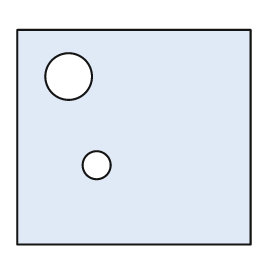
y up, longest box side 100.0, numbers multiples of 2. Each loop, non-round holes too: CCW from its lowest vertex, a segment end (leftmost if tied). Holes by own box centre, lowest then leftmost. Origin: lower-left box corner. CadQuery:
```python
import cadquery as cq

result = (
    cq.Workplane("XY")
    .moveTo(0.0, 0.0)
    .lineTo(100.0, 0.0)
    .lineTo(100.0, 92.0)
    .lineTo(0.0, 92.0)
    .close()
    .moveTo(34.0, 34.0)
    .circle(6.0)
    .moveTo(22.0, 72.0)
    .circle(10.0)
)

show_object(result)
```